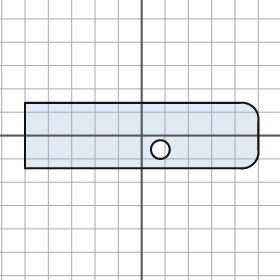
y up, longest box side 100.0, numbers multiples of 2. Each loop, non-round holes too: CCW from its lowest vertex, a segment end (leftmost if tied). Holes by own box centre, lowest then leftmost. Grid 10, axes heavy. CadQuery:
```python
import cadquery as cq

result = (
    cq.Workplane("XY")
    .moveTo(-50.0, -14.0)
    .lineTo(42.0, -14.0)
    .threePointArc((48.0, -12.0), (50.0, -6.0))
    .lineTo(50.0, 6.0)
    .threePointArc((48.0, 12.0), (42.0, 14.0))
    .lineTo(-50.0, 14.0)
    .close()
    .moveTo(8.0, -6.0)
    .circle(4.0)
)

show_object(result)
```